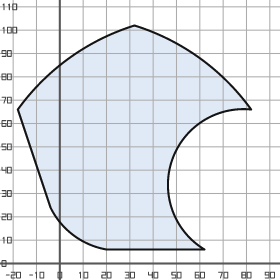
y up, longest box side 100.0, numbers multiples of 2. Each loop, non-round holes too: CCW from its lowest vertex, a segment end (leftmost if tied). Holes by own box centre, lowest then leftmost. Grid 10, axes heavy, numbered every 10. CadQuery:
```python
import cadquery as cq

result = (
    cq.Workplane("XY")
    .moveTo(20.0, 6.0)
    .lineTo(62.0, 6.0)
    .threePointArc((48.0, 44.0), (82.0, 66.0))
    .threePointArc((60.0, 88.0), (32.0, 102.0))
    .threePointArc((4.0, 88.0), (-18.0, 66.0))
    .lineTo(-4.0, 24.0)
    .threePointArc((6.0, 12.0), (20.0, 6.0))
    .close()
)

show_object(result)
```